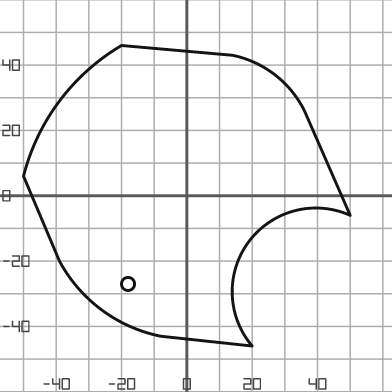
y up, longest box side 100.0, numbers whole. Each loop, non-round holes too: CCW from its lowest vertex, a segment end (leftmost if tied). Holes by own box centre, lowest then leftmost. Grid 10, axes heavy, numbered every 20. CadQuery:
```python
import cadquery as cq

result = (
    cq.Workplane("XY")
    .moveTo(20.0, -46.0)
    .threePointArc((19.0, -14.0), (50.0, -6.0))
    .lineTo(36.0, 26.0)
    .threePointArc((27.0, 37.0), (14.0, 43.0))
    .lineTo(-20.0, 46.0)
    .threePointArc((-39.0, 29.0), (-50.0, 6.0))
    .lineTo(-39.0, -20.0)
    .threePointArc((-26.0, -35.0), (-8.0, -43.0))
    .close()
    .moveTo(-18.0, -27.0)
    .circle(2.0)
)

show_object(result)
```